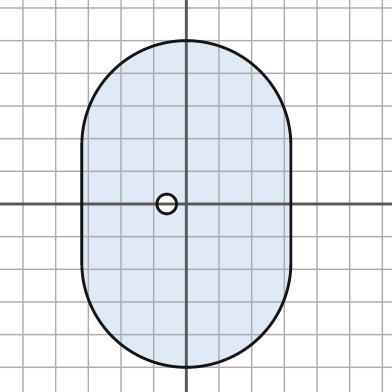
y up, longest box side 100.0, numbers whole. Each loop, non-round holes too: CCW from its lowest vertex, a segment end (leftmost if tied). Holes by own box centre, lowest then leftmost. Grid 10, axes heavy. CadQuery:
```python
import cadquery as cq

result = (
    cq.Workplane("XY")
    .moveTo(-32.0, -18.0)
    .threePointArc((0.0, -50.0), (32.0, -18.0))
    .lineTo(32.0, 18.0)
    .threePointArc((0.0, 50.0), (-32.0, 18.0))
    .close()
    .moveTo(-6.0, 0.0)
    .circle(3.0)
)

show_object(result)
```